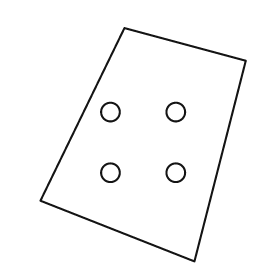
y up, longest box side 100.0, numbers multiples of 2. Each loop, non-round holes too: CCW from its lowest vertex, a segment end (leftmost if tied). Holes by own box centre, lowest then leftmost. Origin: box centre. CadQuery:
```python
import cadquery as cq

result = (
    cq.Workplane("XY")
    .moveTo(22.0, -50.0)
    .lineTo(44.0, 36.0)
    .lineTo(-8.0, 50.0)
    .lineTo(-44.0, -24.0)
    .close()
    .moveTo(-14.0, -12.0)
    .circle(4.0)
    .moveTo(14.0, -12.0)
    .circle(4.0)
    .moveTo(-14.0, 14.0)
    .circle(4.0)
    .moveTo(14.0, 14.0)
    .circle(4.0)
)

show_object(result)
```